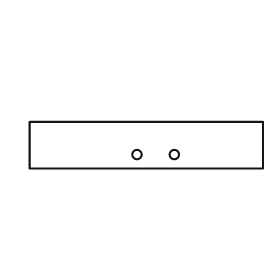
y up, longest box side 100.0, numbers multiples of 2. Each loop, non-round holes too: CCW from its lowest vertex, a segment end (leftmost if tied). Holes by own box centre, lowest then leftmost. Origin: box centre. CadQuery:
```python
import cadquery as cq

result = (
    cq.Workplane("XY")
    .moveTo(-50.0, -10.0)
    .lineTo(50.0, -10.0)
    .lineTo(50.0, 10.0)
    .lineTo(-50.0, 10.0)
    .close()
    .moveTo(-4.0, -4.0)
    .circle(2.0)
    .moveTo(12.0, -4.0)
    .circle(2.0)
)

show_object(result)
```